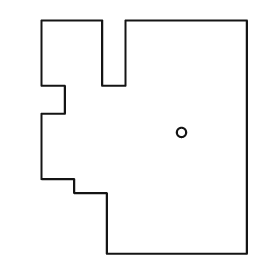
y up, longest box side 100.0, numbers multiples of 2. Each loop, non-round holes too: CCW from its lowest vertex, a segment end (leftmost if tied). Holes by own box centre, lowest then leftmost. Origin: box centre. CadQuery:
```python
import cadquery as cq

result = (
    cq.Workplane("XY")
    .moveTo(-16.0, -50.0)
    .lineTo(44.0, -50.0)
    .lineTo(44.0, 50.0)
    .lineTo(-8.0, 50.0)
    .lineTo(-8.0, 22.0)
    .lineTo(-18.0, 22.0)
    .lineTo(-18.0, 50.0)
    .lineTo(-44.0, 50.0)
    .lineTo(-44.0, 22.0)
    .lineTo(-34.0, 22.0)
    .lineTo(-34.0, 10.0)
    .lineTo(-44.0, 10.0)
    .lineTo(-44.0, -18.0)
    .lineTo(-30.0, -18.0)
    .lineTo(-30.0, -24.0)
    .lineTo(-16.0, -24.0)
    .close()
    .moveTo(16.0, 2.0)
    .circle(2.0)
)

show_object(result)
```